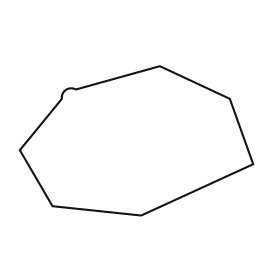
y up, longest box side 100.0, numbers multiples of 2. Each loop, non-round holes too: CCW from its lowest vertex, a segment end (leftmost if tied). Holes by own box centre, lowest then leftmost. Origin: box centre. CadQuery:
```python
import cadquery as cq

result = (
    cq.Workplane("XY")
    .moveTo(2.0, -32.0)
    .lineTo(50.0, -10.0)
    .lineTo(40.0, 18.0)
    .lineTo(10.0, 32.0)
    .lineTo(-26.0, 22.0)
    .threePointArc((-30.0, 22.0), (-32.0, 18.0))
    .lineTo(-50.0, -4.0)
    .lineTo(-36.0, -28.0)
    .close()
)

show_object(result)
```